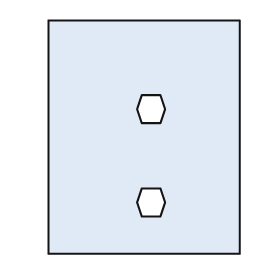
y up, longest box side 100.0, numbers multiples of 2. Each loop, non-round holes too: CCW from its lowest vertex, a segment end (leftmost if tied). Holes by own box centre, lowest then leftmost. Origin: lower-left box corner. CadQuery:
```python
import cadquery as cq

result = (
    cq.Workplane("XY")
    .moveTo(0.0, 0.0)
    .lineTo(82.0, 0.0)
    .lineTo(82.0, 100.0)
    .lineTo(0.0, 100.0)
    .close()
    .moveTo(40.0, 16.0)
    .lineTo(48.0, 16.0)
    .lineTo(50.0, 22.0)
    .lineTo(48.0, 28.0)
    .lineTo(40.0, 28.0)
    .lineTo(38.0, 22.0)
    .close()
    .moveTo(40.0, 56.0)
    .lineTo(48.0, 56.0)
    .lineTo(50.0, 62.0)
    .lineTo(48.0, 68.0)
    .lineTo(40.0, 68.0)
    .lineTo(38.0, 62.0)
    .close()
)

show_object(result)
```